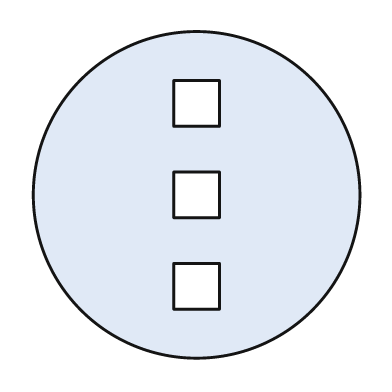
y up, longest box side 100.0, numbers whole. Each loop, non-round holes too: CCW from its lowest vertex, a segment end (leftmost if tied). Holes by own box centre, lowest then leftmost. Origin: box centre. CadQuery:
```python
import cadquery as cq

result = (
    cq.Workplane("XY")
    .moveTo(0.0, 0.0)
    .circle(50.0)
    .moveTo(-7.0, -35.0)
    .lineTo(7.0, -35.0)
    .lineTo(7.0, -21.0)
    .lineTo(-7.0, -21.0)
    .close()
    .moveTo(-7.0, -7.0)
    .lineTo(7.0, -7.0)
    .lineTo(7.0, 7.0)
    .lineTo(-7.0, 7.0)
    .close()
    .moveTo(-7.0, 21.0)
    .lineTo(7.0, 21.0)
    .lineTo(7.0, 35.0)
    .lineTo(-7.0, 35.0)
    .close()
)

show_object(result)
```